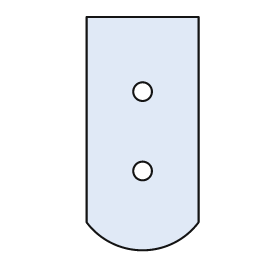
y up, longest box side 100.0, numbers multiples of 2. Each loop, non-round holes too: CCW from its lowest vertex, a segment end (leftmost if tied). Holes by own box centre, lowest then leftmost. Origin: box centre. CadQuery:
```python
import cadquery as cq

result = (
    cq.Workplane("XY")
    .moveTo(-24.0, -38.0)
    .threePointArc((0.0, -50.0), (24.0, -38.0))
    .lineTo(24.0, 50.0)
    .lineTo(-24.0, 50.0)
    .close()
    .moveTo(0.0, -16.0)
    .circle(4.0)
    .moveTo(0.0, 18.0)
    .circle(4.0)
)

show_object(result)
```